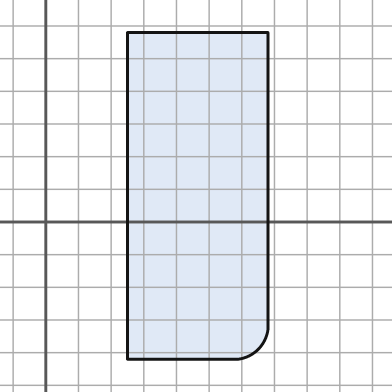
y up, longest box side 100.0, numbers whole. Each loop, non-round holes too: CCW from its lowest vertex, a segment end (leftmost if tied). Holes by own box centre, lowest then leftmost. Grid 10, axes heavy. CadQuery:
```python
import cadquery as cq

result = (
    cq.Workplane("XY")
    .moveTo(25.0, -42.0)
    .lineTo(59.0, -42.0)
    .threePointArc((65.0, -39.0), (68.0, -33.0))
    .lineTo(68.0, 58.0)
    .lineTo(25.0, 58.0)
    .close()
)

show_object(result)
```